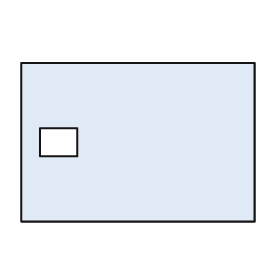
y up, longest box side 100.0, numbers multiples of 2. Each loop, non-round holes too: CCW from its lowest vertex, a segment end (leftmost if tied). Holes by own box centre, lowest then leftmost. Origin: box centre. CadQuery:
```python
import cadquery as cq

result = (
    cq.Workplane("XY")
    .moveTo(-50.0, -34.0)
    .lineTo(50.0, -34.0)
    .lineTo(50.0, 34.0)
    .lineTo(-50.0, 34.0)
    .close()
    .moveTo(-42.0, -6.0)
    .lineTo(-26.0, -6.0)
    .lineTo(-26.0, 6.0)
    .lineTo(-42.0, 6.0)
    .close()
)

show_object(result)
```